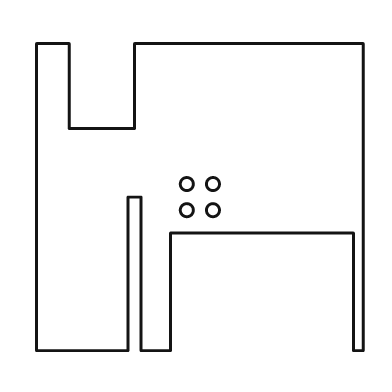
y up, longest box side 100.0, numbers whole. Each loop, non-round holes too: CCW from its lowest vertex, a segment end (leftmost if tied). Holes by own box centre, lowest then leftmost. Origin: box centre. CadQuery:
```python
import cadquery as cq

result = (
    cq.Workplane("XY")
    .moveTo(-50.0, -47.0)
    .lineTo(-22.0, -47.0)
    .lineTo(-22.0, 0.0)
    .lineTo(-18.0, 0.0)
    .lineTo(-18.0, -47.0)
    .lineTo(-9.0, -47.0)
    .lineTo(-9.0, -11.0)
    .lineTo(47.0, -11.0)
    .lineTo(47.0, -47.0)
    .lineTo(50.0, -47.0)
    .lineTo(50.0, 47.0)
    .lineTo(-20.0, 47.0)
    .lineTo(-20.0, 21.0)
    .lineTo(-40.0, 21.0)
    .lineTo(-40.0, 47.0)
    .lineTo(-50.0, 47.0)
    .close()
    .moveTo(-4.0, -4.0)
    .circle(2.0)
    .moveTo(4.0, -4.0)
    .circle(2.0)
    .moveTo(-4.0, 4.0)
    .circle(2.0)
    .moveTo(4.0, 4.0)
    .circle(2.0)
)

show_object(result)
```